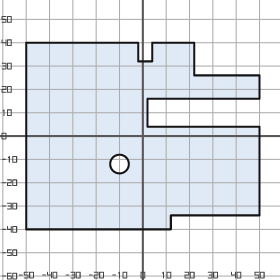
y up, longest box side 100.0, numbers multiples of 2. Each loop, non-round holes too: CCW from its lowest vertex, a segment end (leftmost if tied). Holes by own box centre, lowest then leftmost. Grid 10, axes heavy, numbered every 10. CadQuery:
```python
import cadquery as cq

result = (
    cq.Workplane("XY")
    .moveTo(-50.0, -40.0)
    .lineTo(12.0, -40.0)
    .lineTo(12.0, -34.0)
    .lineTo(50.0, -34.0)
    .lineTo(50.0, 4.0)
    .lineTo(2.0, 4.0)
    .lineTo(2.0, 16.0)
    .lineTo(50.0, 16.0)
    .lineTo(50.0, 26.0)
    .lineTo(22.0, 26.0)
    .lineTo(22.0, 40.0)
    .lineTo(4.0, 40.0)
    .lineTo(4.0, 32.0)
    .lineTo(-2.0, 32.0)
    .lineTo(-2.0, 40.0)
    .lineTo(-50.0, 40.0)
    .close()
    .moveTo(-10.0, -12.0)
    .circle(4.0)
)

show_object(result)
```